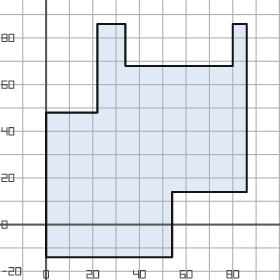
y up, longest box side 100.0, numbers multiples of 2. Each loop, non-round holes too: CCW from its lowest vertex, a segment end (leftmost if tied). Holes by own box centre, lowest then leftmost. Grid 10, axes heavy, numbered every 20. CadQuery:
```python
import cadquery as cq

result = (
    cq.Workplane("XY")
    .moveTo(0.0, -14.0)
    .lineTo(54.0, -14.0)
    .lineTo(54.0, 14.0)
    .lineTo(86.0, 14.0)
    .lineTo(86.0, 86.0)
    .lineTo(80.0, 86.0)
    .lineTo(80.0, 68.0)
    .lineTo(34.0, 68.0)
    .lineTo(34.0, 86.0)
    .lineTo(22.0, 86.0)
    .lineTo(22.0, 48.0)
    .lineTo(0.0, 48.0)
    .close()
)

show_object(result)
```